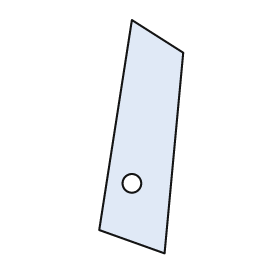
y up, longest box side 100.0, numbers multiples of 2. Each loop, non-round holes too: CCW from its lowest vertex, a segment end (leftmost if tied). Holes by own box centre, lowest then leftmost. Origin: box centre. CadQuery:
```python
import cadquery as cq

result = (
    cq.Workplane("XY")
    .moveTo(10.0, -50.0)
    .lineTo(18.0, 36.0)
    .lineTo(-4.0, 50.0)
    .lineTo(-18.0, -40.0)
    .close()
    .moveTo(-4.0, -20.0)
    .circle(4.0)
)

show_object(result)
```